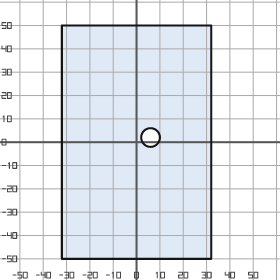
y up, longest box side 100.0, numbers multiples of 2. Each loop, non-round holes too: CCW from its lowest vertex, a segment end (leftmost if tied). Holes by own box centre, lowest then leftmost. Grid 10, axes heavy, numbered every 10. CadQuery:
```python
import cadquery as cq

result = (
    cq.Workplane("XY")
    .moveTo(-32.0, -50.0)
    .lineTo(32.0, -50.0)
    .lineTo(32.0, 50.0)
    .lineTo(-32.0, 50.0)
    .close()
    .moveTo(6.0, 2.0)
    .circle(4.0)
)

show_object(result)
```